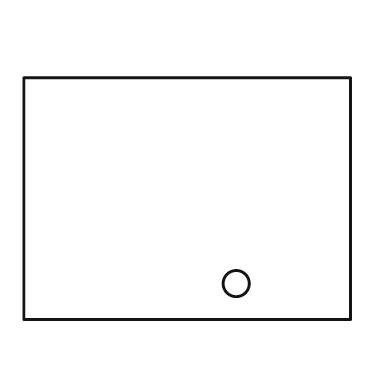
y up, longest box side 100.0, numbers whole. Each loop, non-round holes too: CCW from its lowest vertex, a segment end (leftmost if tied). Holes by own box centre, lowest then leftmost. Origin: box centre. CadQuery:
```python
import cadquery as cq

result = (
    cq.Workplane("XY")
    .moveTo(-50.0, -37.0)
    .lineTo(50.0, -37.0)
    .lineTo(50.0, 37.0)
    .lineTo(-50.0, 37.0)
    .close()
    .moveTo(15.0, -26.0)
    .circle(4.0)
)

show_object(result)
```